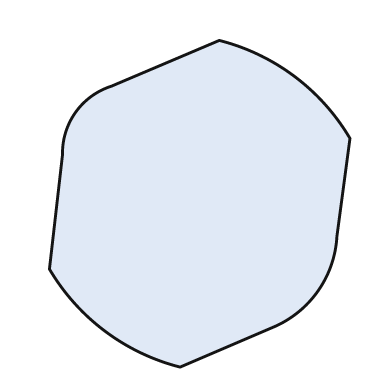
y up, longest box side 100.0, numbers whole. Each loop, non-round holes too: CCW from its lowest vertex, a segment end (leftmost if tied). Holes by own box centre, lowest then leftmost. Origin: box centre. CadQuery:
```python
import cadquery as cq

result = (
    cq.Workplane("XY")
    .moveTo(-6.0, -50.0)
    .lineTo(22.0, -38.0)
    .threePointArc((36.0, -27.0), (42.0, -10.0))
    .lineTo(46.0, 20.0)
    .threePointArc((29.0, 39.0), (6.0, 50.0))
    .lineTo(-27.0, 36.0)
    .threePointArc((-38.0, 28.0), (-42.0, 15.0))
    .lineTo(-46.0, -20.0)
    .threePointArc((-29.0, -39.0), (-6.0, -50.0))
    .close()
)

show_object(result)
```